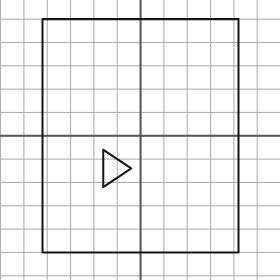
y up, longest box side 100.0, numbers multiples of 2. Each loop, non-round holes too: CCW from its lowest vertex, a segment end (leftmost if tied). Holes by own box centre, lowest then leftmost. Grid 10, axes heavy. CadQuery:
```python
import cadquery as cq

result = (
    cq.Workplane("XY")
    .moveTo(-42.0, -50.0)
    .lineTo(42.0, -50.0)
    .lineTo(42.0, 50.0)
    .lineTo(-42.0, 50.0)
    .close()
    .moveTo(-16.0, -22.0)
    .lineTo(-4.0, -14.0)
    .lineTo(-16.0, -6.0)
    .close()
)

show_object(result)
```